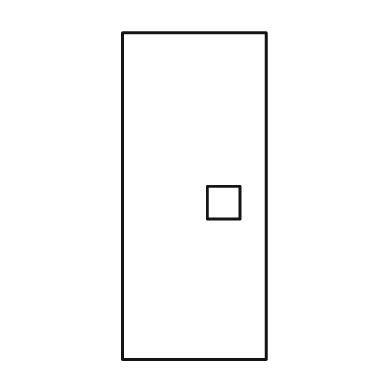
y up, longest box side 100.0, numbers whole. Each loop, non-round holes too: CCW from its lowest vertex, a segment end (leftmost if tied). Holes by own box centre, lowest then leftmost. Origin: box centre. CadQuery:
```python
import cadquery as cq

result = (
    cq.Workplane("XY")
    .moveTo(-22.0, -50.0)
    .lineTo(22.0, -50.0)
    .lineTo(22.0, 50.0)
    .lineTo(-22.0, 50.0)
    .close()
    .moveTo(4.0, -7.0)
    .lineTo(14.0, -7.0)
    .lineTo(14.0, 3.0)
    .lineTo(4.0, 3.0)
    .close()
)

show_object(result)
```